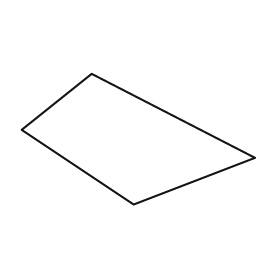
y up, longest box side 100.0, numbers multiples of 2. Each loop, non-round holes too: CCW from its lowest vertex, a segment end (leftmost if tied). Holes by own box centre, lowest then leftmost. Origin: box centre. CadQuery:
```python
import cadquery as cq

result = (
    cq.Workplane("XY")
    .moveTo(-2.0, -28.0)
    .lineTo(50.0, -8.0)
    .lineTo(-20.0, 28.0)
    .lineTo(-50.0, 4.0)
    .close()
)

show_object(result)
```